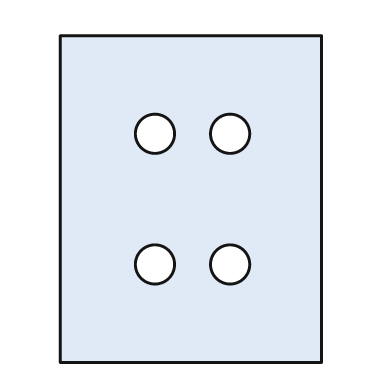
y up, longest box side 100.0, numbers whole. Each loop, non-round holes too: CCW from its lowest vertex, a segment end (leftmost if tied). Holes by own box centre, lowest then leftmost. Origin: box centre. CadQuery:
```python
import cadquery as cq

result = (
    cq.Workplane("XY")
    .moveTo(-40.0, -50.0)
    .lineTo(40.0, -50.0)
    .lineTo(40.0, 50.0)
    .lineTo(-40.0, 50.0)
    .close()
    .moveTo(-11.0, -20.0)
    .circle(6.0)
    .moveTo(12.0, -20.0)
    .circle(6.0)
    .moveTo(-11.0, 20.0)
    .circle(6.0)
    .moveTo(12.0, 20.0)
    .circle(6.0)
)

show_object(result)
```